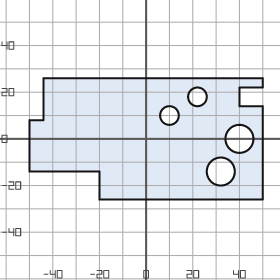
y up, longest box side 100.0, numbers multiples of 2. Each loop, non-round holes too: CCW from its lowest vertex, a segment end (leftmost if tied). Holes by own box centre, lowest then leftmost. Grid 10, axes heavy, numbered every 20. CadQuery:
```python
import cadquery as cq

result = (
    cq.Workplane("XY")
    .moveTo(-20.0, -26.0)
    .lineTo(50.0, -26.0)
    .lineTo(50.0, 14.0)
    .lineTo(40.0, 14.0)
    .lineTo(40.0, 22.0)
    .lineTo(50.0, 22.0)
    .lineTo(50.0, 26.0)
    .lineTo(-44.0, 26.0)
    .lineTo(-44.0, 8.0)
    .lineTo(-50.0, 8.0)
    .lineTo(-50.0, -14.0)
    .lineTo(-20.0, -14.0)
    .close()
    .moveTo(32.0, -14.0)
    .circle(6.0)
    .moveTo(40.0, 0.0)
    .circle(6.0)
    .moveTo(10.0, 10.0)
    .circle(4.0)
    .moveTo(22.0, 18.0)
    .circle(4.0)
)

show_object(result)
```